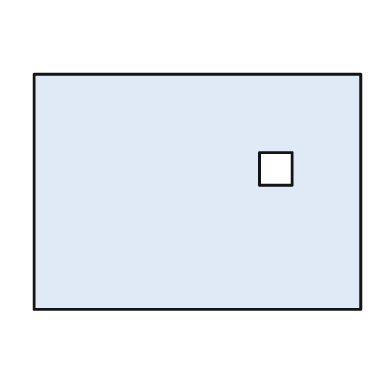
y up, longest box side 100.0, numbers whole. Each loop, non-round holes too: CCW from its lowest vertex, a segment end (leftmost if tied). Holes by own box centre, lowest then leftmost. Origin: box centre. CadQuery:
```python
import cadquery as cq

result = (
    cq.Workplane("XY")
    .moveTo(-50.0, -36.0)
    .lineTo(50.0, -36.0)
    .lineTo(50.0, 36.0)
    .lineTo(-50.0, 36.0)
    .close()
    .moveTo(19.0, 2.0)
    .lineTo(29.0, 2.0)
    .lineTo(29.0, 12.0)
    .lineTo(19.0, 12.0)
    .close()
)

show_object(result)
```